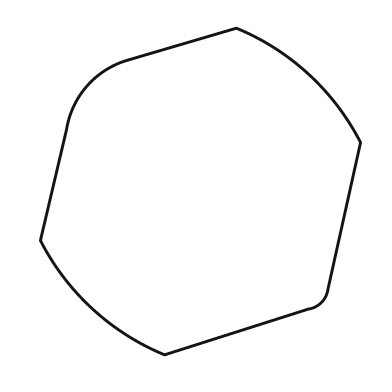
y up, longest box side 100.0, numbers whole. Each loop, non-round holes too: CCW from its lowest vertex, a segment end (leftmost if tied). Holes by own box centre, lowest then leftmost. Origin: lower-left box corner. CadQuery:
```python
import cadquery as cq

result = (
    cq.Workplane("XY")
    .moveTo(38.0, 0.0)
    .lineTo(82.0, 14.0)
    .threePointArc((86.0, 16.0), (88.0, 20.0))
    .lineTo(98.0, 65.0)
    .threePointArc((82.0, 86.0), (60.0, 100.0))
    .lineTo(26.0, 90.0)
    .threePointArc((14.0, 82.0), (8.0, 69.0))
    .lineTo(0.0, 35.0)
    .threePointArc((16.0, 14.0), (38.0, 0.0))
    .close()
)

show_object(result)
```